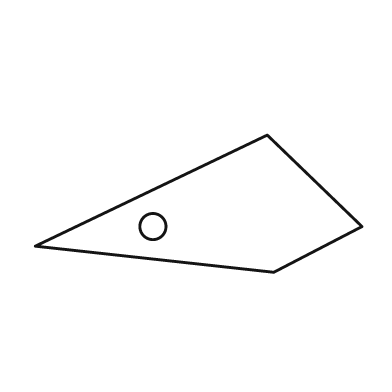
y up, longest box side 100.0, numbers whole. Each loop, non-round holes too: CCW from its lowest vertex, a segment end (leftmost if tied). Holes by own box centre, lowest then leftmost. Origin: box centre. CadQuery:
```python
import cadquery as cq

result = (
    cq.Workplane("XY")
    .moveTo(23.0, -21.0)
    .lineTo(50.0, -7.0)
    .lineTo(21.0, 21.0)
    .lineTo(-50.0, -13.0)
    .close()
    .moveTo(-14.0, -7.0)
    .circle(4.0)
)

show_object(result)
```